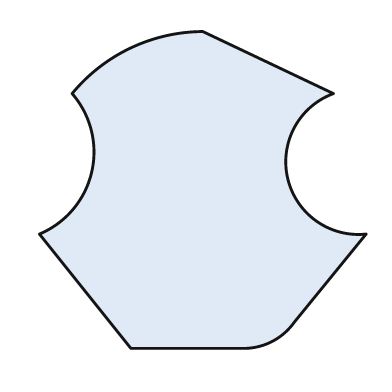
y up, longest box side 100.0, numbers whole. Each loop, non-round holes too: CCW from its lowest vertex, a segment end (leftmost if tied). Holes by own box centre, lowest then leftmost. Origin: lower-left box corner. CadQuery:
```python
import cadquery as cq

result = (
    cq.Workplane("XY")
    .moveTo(28.0, 0.0)
    .lineTo(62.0, 0.0)
    .threePointArc((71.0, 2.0), (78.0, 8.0))
    .lineTo(100.0, 35.0)
    .threePointArc((76.0, 52.0), (90.0, 78.0))
    .lineTo(50.0, 97.0)
    .threePointArc((28.0, 92.0), (10.0, 78.0))
    .threePointArc((16.0, 54.0), (0.0, 35.0))
    .close()
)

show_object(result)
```